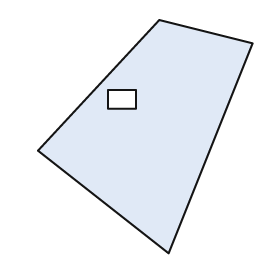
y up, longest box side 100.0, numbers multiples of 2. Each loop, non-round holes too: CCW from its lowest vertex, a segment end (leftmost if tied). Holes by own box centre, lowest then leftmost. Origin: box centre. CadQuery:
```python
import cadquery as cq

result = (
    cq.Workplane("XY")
    .moveTo(10.0, -50.0)
    .lineTo(46.0, 40.0)
    .lineTo(6.0, 50.0)
    .lineTo(-46.0, -6.0)
    .close()
    .moveTo(-16.0, 12.0)
    .lineTo(-4.0, 12.0)
    .lineTo(-4.0, 20.0)
    .lineTo(-16.0, 20.0)
    .close()
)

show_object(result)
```